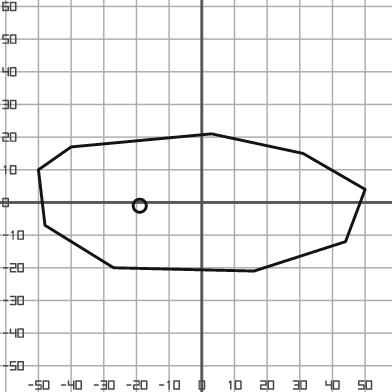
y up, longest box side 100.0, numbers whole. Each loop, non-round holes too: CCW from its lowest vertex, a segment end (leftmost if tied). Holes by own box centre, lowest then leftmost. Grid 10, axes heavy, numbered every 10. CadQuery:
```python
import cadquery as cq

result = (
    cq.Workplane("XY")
    .moveTo(16.0, -21.0)
    .lineTo(44.0, -12.0)
    .lineTo(50.0, 4.0)
    .lineTo(31.0, 15.0)
    .lineTo(3.0, 21.0)
    .lineTo(-40.0, 17.0)
    .lineTo(-50.0, 10.0)
    .lineTo(-48.0, -7.0)
    .lineTo(-27.0, -20.0)
    .close()
    .moveTo(-19.0, -1.0)
    .circle(2.0)
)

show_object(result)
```